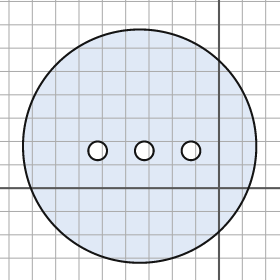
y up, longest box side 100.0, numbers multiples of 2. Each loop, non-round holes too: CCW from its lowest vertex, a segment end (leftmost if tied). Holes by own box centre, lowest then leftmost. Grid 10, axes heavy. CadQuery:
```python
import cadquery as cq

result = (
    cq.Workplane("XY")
    .moveTo(-34.0, 18.0)
    .circle(50.0)
    .moveTo(-52.0, 16.0)
    .circle(4.0)
    .moveTo(-32.0, 16.0)
    .circle(4.0)
    .moveTo(-12.0, 16.0)
    .circle(4.0)
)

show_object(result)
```